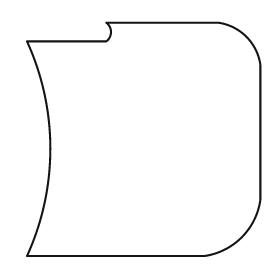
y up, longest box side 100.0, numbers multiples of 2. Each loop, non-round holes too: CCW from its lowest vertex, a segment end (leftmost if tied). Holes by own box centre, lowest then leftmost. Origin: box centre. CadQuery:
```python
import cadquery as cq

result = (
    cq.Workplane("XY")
    .moveTo(-50.0, -50.0)
    .lineTo(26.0, -50.0)
    .threePointArc((42.0, -42.0), (50.0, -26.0))
    .lineTo(50.0, 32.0)
    .threePointArc((44.0, 44.0), (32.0, 50.0))
    .lineTo(-16.0, 50.0)
    .threePointArc((-14.0, 46.0), (-16.0, 42.0))
    .lineTo(-50.0, 42.0)
    .threePointArc((-40.0, -4.0), (-50.0, -50.0))
    .close()
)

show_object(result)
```